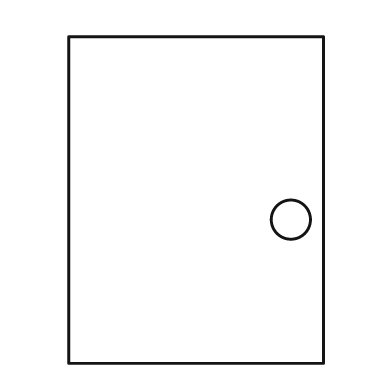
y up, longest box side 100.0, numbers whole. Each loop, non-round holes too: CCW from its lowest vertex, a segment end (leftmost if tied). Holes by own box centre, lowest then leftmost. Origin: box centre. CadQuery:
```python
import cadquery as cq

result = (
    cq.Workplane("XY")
    .moveTo(-39.0, -50.0)
    .lineTo(39.0, -50.0)
    .lineTo(39.0, 50.0)
    .lineTo(-39.0, 50.0)
    .close()
    .moveTo(29.0, -6.0)
    .circle(6.0)
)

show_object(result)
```